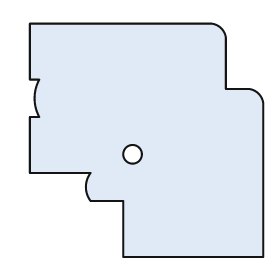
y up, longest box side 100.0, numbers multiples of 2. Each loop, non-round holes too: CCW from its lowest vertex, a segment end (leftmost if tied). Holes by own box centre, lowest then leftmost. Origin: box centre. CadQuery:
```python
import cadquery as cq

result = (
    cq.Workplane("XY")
    .moveTo(-10.0, -50.0)
    .lineTo(50.0, -50.0)
    .lineTo(50.0, 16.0)
    .threePointArc((48.0, 20.0), (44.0, 22.0))
    .lineTo(34.0, 22.0)
    .lineTo(34.0, 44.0)
    .threePointArc((32.0, 48.0), (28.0, 50.0))
    .lineTo(-50.0, 50.0)
    .lineTo(-50.0, 26.0)
    .lineTo(-46.0, 26.0)
    .threePointArc((-48.0, 18.0), (-46.0, 10.0))
    .lineTo(-50.0, 10.0)
    .lineTo(-50.0, -14.0)
    .lineTo(-24.0, -14.0)
    .threePointArc((-26.0, -20.0), (-24.0, -26.0))
    .lineTo(-10.0, -26.0)
    .close()
    .moveTo(-6.0, -6.0)
    .circle(4.0)
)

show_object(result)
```